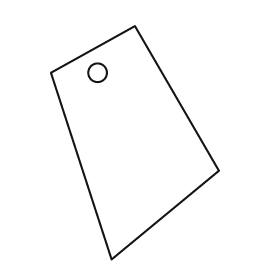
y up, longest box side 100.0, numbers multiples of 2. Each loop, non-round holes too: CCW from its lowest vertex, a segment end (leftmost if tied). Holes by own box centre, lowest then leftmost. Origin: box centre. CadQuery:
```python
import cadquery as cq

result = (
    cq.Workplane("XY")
    .moveTo(-10.0, -50.0)
    .lineTo(36.0, -12.0)
    .lineTo(0.0, 50.0)
    .lineTo(-36.0, 30.0)
    .close()
    .moveTo(-16.0, 30.0)
    .circle(4.0)
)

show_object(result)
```